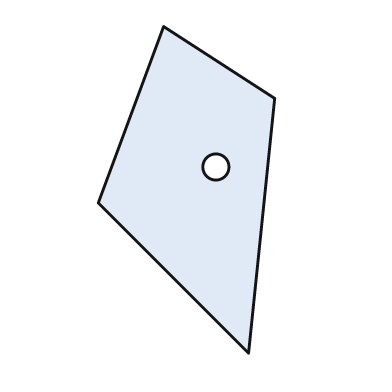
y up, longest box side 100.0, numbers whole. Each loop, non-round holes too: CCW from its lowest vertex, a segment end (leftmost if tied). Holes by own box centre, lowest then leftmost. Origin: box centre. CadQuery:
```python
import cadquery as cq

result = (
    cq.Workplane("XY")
    .moveTo(19.0, -50.0)
    .lineTo(27.0, 28.0)
    .lineTo(-7.0, 50.0)
    .lineTo(-27.0, -4.0)
    .close()
    .moveTo(9.0, 7.0)
    .circle(4.0)
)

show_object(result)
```